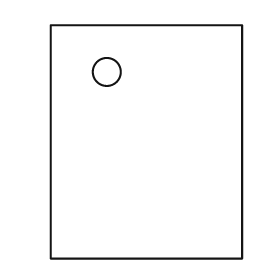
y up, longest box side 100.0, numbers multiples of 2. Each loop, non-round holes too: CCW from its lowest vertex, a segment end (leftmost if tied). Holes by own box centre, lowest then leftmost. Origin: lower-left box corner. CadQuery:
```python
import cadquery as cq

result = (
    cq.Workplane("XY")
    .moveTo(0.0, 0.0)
    .lineTo(82.0, 0.0)
    .lineTo(82.0, 100.0)
    .lineTo(0.0, 100.0)
    .close()
    .moveTo(24.0, 80.0)
    .circle(6.0)
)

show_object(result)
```